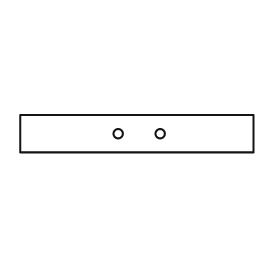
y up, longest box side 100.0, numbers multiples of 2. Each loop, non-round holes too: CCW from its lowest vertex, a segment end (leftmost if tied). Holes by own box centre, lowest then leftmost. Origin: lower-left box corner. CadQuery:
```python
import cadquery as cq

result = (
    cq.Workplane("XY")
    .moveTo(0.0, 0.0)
    .lineTo(100.0, 0.0)
    .lineTo(100.0, 16.0)
    .lineTo(0.0, 16.0)
    .close()
    .moveTo(42.0, 8.0)
    .circle(2.0)
    .moveTo(60.0, 8.0)
    .circle(2.0)
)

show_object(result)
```